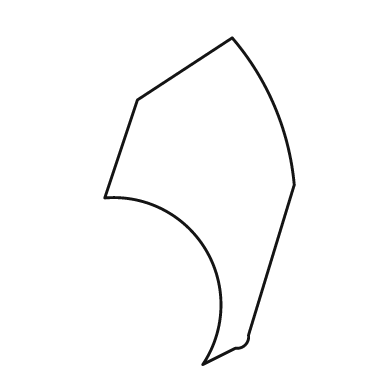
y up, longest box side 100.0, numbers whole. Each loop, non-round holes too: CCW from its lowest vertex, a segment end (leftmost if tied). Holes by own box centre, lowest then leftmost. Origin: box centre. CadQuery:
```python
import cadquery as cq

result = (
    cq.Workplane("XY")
    .moveTo(1.0, -50.0)
    .lineTo(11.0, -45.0)
    .threePointArc((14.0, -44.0), (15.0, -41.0))
    .lineTo(29.0, 5.0)
    .threePointArc((23.0, 29.0), (10.0, 50.0))
    .lineTo(-19.0, 31.0)
    .lineTo(-29.0, 1.0)
    .threePointArc((2.0, -15.0), (1.0, -50.0))
    .close()
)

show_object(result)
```